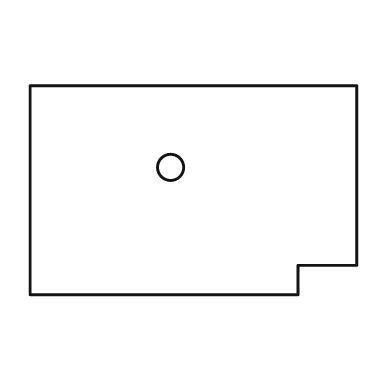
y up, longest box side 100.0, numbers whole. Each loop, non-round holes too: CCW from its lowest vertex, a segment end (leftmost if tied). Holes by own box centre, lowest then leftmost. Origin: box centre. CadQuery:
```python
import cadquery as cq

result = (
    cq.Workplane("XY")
    .moveTo(-50.0, -32.0)
    .lineTo(32.0, -32.0)
    .lineTo(32.0, -23.0)
    .lineTo(50.0, -23.0)
    .lineTo(50.0, 32.0)
    .lineTo(-50.0, 32.0)
    .close()
    .moveTo(-7.0, 7.0)
    .circle(4.0)
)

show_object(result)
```